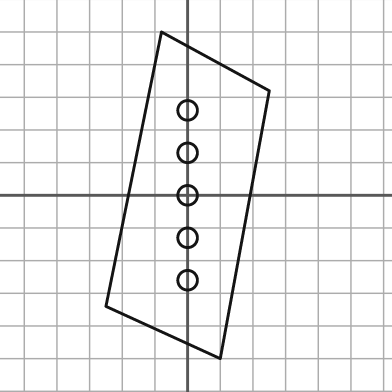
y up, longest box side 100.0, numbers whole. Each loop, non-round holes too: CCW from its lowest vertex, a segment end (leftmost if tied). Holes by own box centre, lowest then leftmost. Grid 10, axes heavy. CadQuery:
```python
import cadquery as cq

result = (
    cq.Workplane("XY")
    .moveTo(10.0, -50.0)
    .lineTo(25.0, 32.0)
    .lineTo(-8.0, 50.0)
    .lineTo(-25.0, -34.0)
    .close()
    .moveTo(0.0, -26.0)
    .circle(3.0)
    .moveTo(0.0, -13.0)
    .circle(3.0)
    .moveTo(0.0, 0.0)
    .circle(3.0)
    .moveTo(0.0, 13.0)
    .circle(3.0)
    .moveTo(0.0, 26.0)
    .circle(3.0)
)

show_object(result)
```